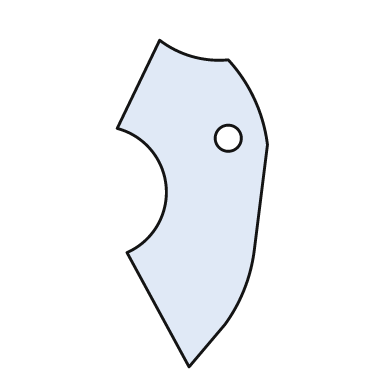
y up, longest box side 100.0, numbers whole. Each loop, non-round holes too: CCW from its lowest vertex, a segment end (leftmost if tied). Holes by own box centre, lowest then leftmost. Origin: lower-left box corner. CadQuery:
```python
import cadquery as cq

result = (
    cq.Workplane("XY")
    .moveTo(22.0, 0.0)
    .lineTo(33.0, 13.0)
    .threePointArc((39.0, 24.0), (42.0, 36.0))
    .lineTo(46.0, 68.0)
    .threePointArc((42.0, 82.0), (34.0, 94.0))
    .threePointArc((23.0, 95.0), (13.0, 100.0))
    .lineTo(0.0, 73.0)
    .threePointArc((15.0, 55.0), (3.0, 35.0))
    .close()
    .moveTo(34.0, 70.0)
    .circle(4.0)
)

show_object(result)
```